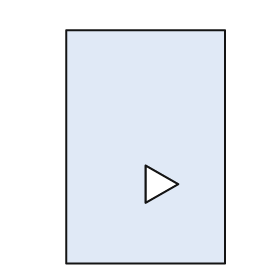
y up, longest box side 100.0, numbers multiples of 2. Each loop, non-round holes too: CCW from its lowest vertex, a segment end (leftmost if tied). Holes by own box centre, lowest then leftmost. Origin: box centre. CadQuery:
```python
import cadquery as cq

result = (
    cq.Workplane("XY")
    .moveTo(-34.0, -50.0)
    .lineTo(34.0, -50.0)
    .lineTo(34.0, 50.0)
    .lineTo(-34.0, 50.0)
    .close()
    .moveTo(0.0, -24.0)
    .lineTo(14.0, -16.0)
    .lineTo(0.0, -8.0)
    .close()
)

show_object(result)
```